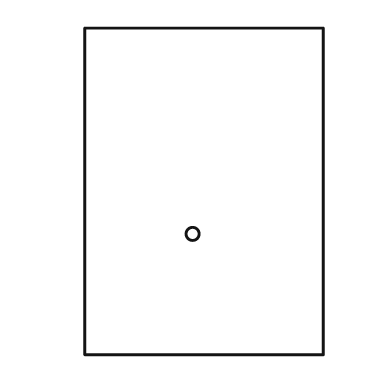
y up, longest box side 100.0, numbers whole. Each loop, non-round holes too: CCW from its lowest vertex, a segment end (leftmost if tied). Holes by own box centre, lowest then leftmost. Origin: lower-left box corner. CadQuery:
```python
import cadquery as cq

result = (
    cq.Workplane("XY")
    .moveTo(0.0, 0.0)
    .lineTo(73.0, 0.0)
    .lineTo(73.0, 100.0)
    .lineTo(0.0, 100.0)
    .close()
    .moveTo(33.0, 37.0)
    .circle(2.0)
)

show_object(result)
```